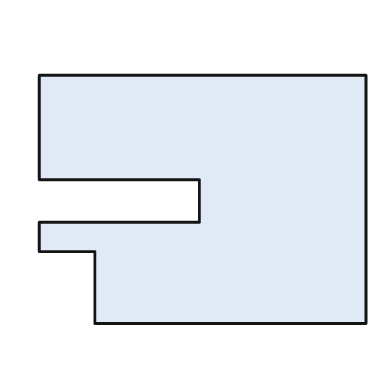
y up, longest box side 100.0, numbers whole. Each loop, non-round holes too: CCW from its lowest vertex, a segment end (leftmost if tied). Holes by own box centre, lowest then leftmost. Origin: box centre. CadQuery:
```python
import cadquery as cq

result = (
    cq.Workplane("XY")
    .moveTo(-33.0, -38.0)
    .lineTo(50.0, -38.0)
    .lineTo(50.0, 38.0)
    .lineTo(-50.0, 38.0)
    .lineTo(-50.0, 6.0)
    .lineTo(-1.0, 6.0)
    .lineTo(-1.0, -7.0)
    .lineTo(-50.0, -7.0)
    .lineTo(-50.0, -16.0)
    .lineTo(-33.0, -16.0)
    .close()
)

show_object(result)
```